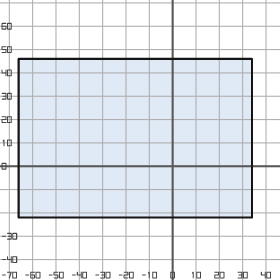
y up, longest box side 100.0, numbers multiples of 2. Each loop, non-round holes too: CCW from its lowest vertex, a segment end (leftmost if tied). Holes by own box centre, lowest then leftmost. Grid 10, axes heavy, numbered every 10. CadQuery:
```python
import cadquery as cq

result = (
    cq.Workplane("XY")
    .moveTo(-66.0, -22.0)
    .lineTo(34.0, -22.0)
    .lineTo(34.0, 46.0)
    .lineTo(-66.0, 46.0)
    .close()
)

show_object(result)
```